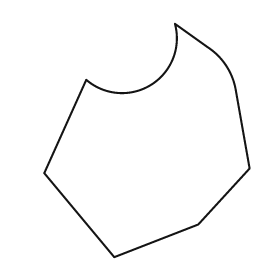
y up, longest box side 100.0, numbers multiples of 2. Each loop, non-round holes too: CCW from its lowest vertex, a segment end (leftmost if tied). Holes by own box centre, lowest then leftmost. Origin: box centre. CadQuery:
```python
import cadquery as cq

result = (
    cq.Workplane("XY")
    .moveTo(-14.0, -50.0)
    .lineTo(22.0, -36.0)
    .lineTo(44.0, -12.0)
    .lineTo(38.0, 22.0)
    .threePointArc((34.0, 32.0), (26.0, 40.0))
    .lineTo(12.0, 50.0)
    .threePointArc((2.0, 24.0), (-26.0, 26.0))
    .lineTo(-44.0, -14.0)
    .close()
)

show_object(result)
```